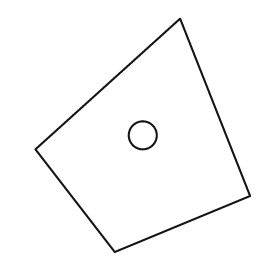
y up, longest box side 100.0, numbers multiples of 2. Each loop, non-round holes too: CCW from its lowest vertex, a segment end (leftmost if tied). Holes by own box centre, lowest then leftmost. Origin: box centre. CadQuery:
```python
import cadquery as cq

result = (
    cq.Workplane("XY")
    .moveTo(-12.0, -50.0)
    .lineTo(46.0, -26.0)
    .lineTo(16.0, 50.0)
    .lineTo(-46.0, -6.0)
    .close()
    .moveTo(0.0, 0.0)
    .circle(6.0)
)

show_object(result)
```